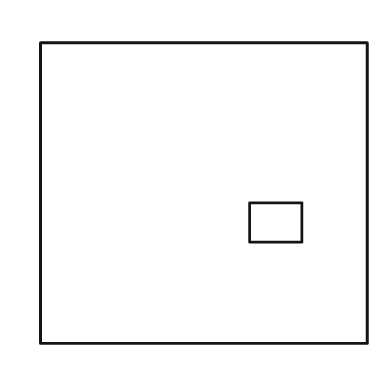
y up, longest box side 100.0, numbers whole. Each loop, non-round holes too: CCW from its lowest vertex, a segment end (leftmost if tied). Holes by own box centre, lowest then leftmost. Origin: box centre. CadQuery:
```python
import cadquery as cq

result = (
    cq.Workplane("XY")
    .moveTo(-50.0, -46.0)
    .lineTo(50.0, -46.0)
    .lineTo(50.0, 46.0)
    .lineTo(-50.0, 46.0)
    .close()
    .moveTo(14.0, -15.0)
    .lineTo(30.0, -15.0)
    .lineTo(30.0, -3.0)
    .lineTo(14.0, -3.0)
    .close()
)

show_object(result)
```